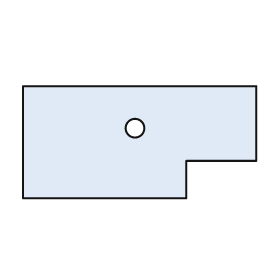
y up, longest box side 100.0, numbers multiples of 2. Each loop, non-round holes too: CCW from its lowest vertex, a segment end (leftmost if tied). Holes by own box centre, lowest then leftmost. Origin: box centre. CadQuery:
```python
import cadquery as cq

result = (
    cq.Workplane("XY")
    .moveTo(-50.0, -24.0)
    .lineTo(20.0, -24.0)
    .lineTo(20.0, -8.0)
    .lineTo(50.0, -8.0)
    .lineTo(50.0, 24.0)
    .lineTo(-50.0, 24.0)
    .close()
    .moveTo(-2.0, 6.0)
    .circle(4.0)
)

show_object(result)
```